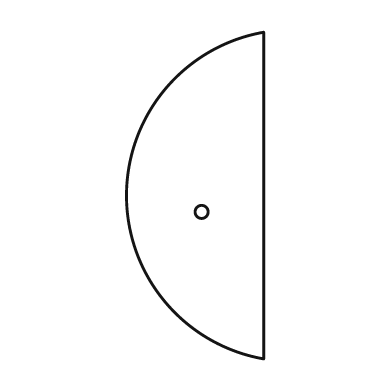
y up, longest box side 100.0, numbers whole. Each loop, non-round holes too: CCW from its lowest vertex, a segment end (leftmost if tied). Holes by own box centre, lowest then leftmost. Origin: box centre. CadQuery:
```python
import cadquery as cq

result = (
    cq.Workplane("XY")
    .moveTo(21.0, -50.0)
    .lineTo(21.0, 50.0)
    .threePointArc((-21.0, 0.0), (21.0, -50.0))
    .close()
    .moveTo(2.0, -5.0)
    .circle(2.0)
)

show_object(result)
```